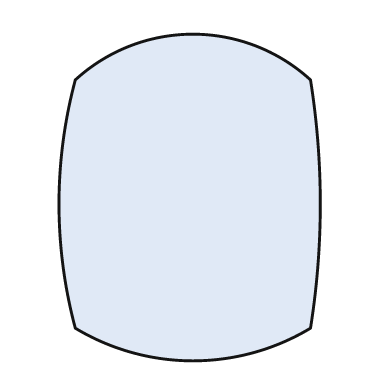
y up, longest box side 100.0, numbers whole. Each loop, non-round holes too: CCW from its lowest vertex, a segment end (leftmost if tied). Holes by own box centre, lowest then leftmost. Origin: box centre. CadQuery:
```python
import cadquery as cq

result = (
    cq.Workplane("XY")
    .moveTo(-35.0, -40.0)
    .threePointArc((1.0, -50.0), (37.0, -40.0))
    .threePointArc((40.0, -2.0), (37.0, 36.0))
    .threePointArc((1.0, 50.0), (-35.0, 36.0))
    .threePointArc((-40.0, -2.0), (-35.0, -40.0))
    .close()
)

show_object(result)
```